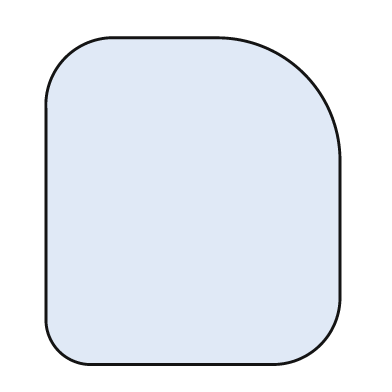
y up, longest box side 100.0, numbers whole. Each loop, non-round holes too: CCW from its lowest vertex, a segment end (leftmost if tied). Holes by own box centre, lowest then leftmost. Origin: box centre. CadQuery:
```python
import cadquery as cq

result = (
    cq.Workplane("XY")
    .moveTo(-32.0, -50.0)
    .lineTo(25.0, -50.0)
    .threePointArc((39.0, -44.0), (45.0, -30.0))
    .lineTo(45.0, 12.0)
    .threePointArc((34.0, 39.0), (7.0, 50.0))
    .lineTo(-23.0, 50.0)
    .threePointArc((-39.0, 44.0), (-45.0, 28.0))
    .lineTo(-45.0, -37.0)
    .threePointArc((-41.0, -46.0), (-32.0, -50.0))
    .close()
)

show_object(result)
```